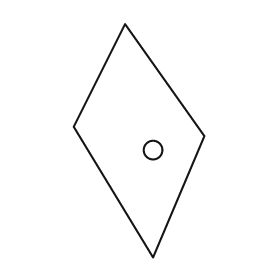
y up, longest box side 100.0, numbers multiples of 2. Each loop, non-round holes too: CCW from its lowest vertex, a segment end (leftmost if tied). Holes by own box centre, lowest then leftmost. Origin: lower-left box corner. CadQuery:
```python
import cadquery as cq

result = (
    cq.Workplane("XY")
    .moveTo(34.0, 0.0)
    .lineTo(56.0, 52.0)
    .lineTo(22.0, 100.0)
    .lineTo(0.0, 56.0)
    .close()
    .moveTo(34.0, 46.0)
    .circle(4.0)
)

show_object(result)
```